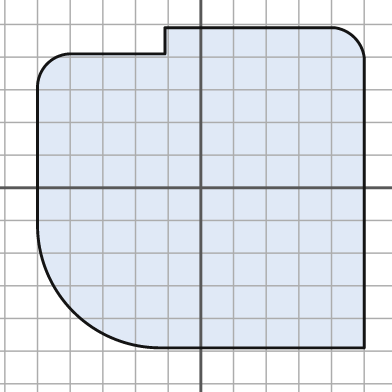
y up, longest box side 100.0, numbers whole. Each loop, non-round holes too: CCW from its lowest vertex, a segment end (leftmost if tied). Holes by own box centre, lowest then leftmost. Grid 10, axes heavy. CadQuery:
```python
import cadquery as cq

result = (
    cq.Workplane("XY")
    .moveTo(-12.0, -49.0)
    .lineTo(50.0, -49.0)
    .lineTo(50.0, 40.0)
    .threePointArc((47.0, 46.0), (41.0, 49.0))
    .lineTo(-11.0, 49.0)
    .lineTo(-11.0, 41.0)
    .lineTo(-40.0, 41.0)
    .threePointArc((-47.0, 38.0), (-50.0, 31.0))
    .lineTo(-50.0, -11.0)
    .threePointArc((-39.0, -38.0), (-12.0, -49.0))
    .close()
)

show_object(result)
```